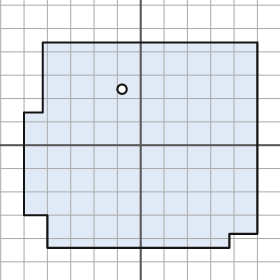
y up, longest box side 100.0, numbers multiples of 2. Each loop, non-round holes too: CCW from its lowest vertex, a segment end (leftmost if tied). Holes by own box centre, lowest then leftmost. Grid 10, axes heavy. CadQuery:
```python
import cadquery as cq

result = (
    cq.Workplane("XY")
    .moveTo(-40.0, -44.0)
    .lineTo(38.0, -44.0)
    .lineTo(38.0, -38.0)
    .lineTo(50.0, -38.0)
    .lineTo(50.0, 44.0)
    .lineTo(-42.0, 44.0)
    .lineTo(-42.0, 14.0)
    .lineTo(-50.0, 14.0)
    .lineTo(-50.0, -30.0)
    .lineTo(-40.0, -30.0)
    .close()
    .moveTo(-8.0, 24.0)
    .circle(2.0)
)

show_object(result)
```